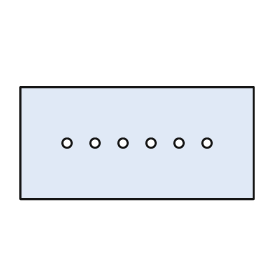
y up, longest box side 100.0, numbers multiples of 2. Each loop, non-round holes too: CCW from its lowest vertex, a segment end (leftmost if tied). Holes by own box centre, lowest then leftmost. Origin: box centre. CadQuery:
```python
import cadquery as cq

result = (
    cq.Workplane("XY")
    .moveTo(-50.0, -24.0)
    .lineTo(50.0, -24.0)
    .lineTo(50.0, 24.0)
    .lineTo(-50.0, 24.0)
    .close()
    .moveTo(-30.0, 0.0)
    .circle(2.0)
    .moveTo(-18.0, 0.0)
    .circle(2.0)
    .moveTo(-6.0, 0.0)
    .circle(2.0)
    .moveTo(6.0, 0.0)
    .circle(2.0)
    .moveTo(18.0, 0.0)
    .circle(2.0)
    .moveTo(30.0, 0.0)
    .circle(2.0)
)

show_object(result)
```